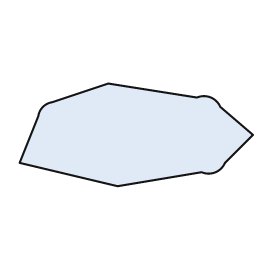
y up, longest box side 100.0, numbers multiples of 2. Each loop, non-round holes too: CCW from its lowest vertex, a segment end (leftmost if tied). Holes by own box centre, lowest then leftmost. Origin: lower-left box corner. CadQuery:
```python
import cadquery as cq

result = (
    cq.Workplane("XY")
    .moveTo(42.0, 0.0)
    .lineTo(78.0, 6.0)
    .threePointArc((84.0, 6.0), (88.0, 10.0))
    .lineTo(100.0, 22.0)
    .lineTo(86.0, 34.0)
    .threePointArc((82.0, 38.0), (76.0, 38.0))
    .lineTo(38.0, 44.0)
    .lineTo(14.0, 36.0)
    .threePointArc((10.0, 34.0), (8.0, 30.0))
    .lineTo(0.0, 10.0)
    .close()
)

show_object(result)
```